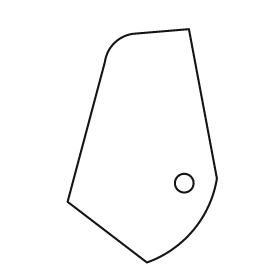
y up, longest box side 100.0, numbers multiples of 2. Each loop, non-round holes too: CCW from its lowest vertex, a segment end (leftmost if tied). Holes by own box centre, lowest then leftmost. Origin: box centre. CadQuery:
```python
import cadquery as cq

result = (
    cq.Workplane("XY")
    .moveTo(2.0, -50.0)
    .threePointArc((22.0, -36.0), (32.0, -14.0))
    .lineTo(20.0, 50.0)
    .lineTo(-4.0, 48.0)
    .threePointArc((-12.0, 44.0), (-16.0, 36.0))
    .lineTo(-32.0, -24.0)
    .close()
    .moveTo(18.0, -16.0)
    .circle(4.0)
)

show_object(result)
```